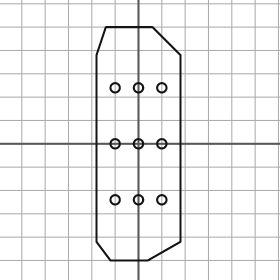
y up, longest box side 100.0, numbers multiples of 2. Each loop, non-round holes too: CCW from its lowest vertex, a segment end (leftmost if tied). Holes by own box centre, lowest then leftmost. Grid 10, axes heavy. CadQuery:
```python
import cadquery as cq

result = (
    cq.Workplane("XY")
    .moveTo(-12.0, -50.0)
    .lineTo(4.0, -50.0)
    .lineTo(18.0, -42.0)
    .lineTo(18.0, 38.0)
    .lineTo(6.0, 50.0)
    .lineTo(-14.0, 50.0)
    .lineTo(-18.0, 38.0)
    .lineTo(-18.0, -42.0)
    .close()
    .moveTo(-10.0, -24.0)
    .circle(2.0)
    .moveTo(0.0, -24.0)
    .circle(2.0)
    .moveTo(10.0, -24.0)
    .circle(2.0)
    .moveTo(-10.0, 0.0)
    .circle(2.0)
    .moveTo(0.0, 0.0)
    .circle(2.0)
    .moveTo(10.0, 0.0)
    .circle(2.0)
    .moveTo(-10.0, 24.0)
    .circle(2.0)
    .moveTo(0.0, 24.0)
    .circle(2.0)
    .moveTo(10.0, 24.0)
    .circle(2.0)
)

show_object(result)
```